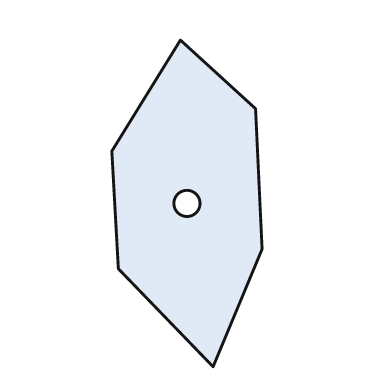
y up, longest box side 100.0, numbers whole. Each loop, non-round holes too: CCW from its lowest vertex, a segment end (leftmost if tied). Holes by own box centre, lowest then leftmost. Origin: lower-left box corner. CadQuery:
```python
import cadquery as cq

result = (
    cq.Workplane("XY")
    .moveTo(31.0, 0.0)
    .lineTo(46.0, 36.0)
    .lineTo(44.0, 79.0)
    .lineTo(21.0, 100.0)
    .lineTo(0.0, 66.0)
    .lineTo(2.0, 30.0)
    .close()
    .moveTo(23.0, 50.0)
    .circle(4.0)
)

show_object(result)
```